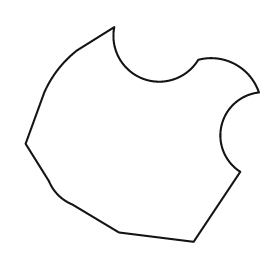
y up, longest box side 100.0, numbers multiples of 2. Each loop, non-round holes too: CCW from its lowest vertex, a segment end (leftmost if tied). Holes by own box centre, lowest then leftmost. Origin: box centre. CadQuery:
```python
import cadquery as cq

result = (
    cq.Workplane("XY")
    .moveTo(22.0, -46.0)
    .lineTo(42.0, -16.0)
    .threePointArc((34.0, 4.0), (50.0, 18.0))
    .threePointArc((40.0, 30.0), (24.0, 32.0))
    .threePointArc((0.0, 24.0), (-12.0, 46.0))
    .lineTo(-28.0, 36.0)
    .threePointArc((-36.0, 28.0), (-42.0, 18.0))
    .lineTo(-50.0, -4.0)
    .lineTo(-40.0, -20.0)
    .threePointArc((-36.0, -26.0), (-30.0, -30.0))
    .lineTo(-10.0, -42.0)
    .close()
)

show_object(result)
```